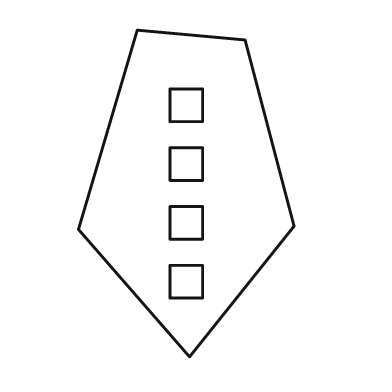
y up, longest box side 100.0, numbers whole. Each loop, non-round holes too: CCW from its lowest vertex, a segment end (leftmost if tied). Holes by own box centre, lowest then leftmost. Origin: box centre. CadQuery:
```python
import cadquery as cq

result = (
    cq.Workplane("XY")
    .moveTo(1.0, -50.0)
    .lineTo(33.0, -10.0)
    .lineTo(18.0, 47.0)
    .lineTo(-15.0, 50.0)
    .lineTo(-33.0, -11.0)
    .close()
    .moveTo(-5.0, -32.0)
    .lineTo(5.0, -32.0)
    .lineTo(5.0, -22.0)
    .lineTo(-5.0, -22.0)
    .close()
    .moveTo(-5.0, -14.0)
    .lineTo(5.0, -14.0)
    .lineTo(5.0, -4.0)
    .lineTo(-5.0, -4.0)
    .close()
    .moveTo(-5.0, 4.0)
    .lineTo(5.0, 4.0)
    .lineTo(5.0, 14.0)
    .lineTo(-5.0, 14.0)
    .close()
    .moveTo(-5.0, 22.0)
    .lineTo(5.0, 22.0)
    .lineTo(5.0, 32.0)
    .lineTo(-5.0, 32.0)
    .close()
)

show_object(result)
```